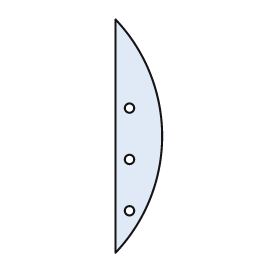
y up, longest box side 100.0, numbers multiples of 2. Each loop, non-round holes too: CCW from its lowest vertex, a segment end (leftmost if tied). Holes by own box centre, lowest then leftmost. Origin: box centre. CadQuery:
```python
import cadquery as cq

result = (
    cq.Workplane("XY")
    .moveTo(-10.0, -50.0)
    .threePointArc((10.0, 0.0), (-10.0, 50.0))
    .close()
    .moveTo(-4.0, -32.0)
    .circle(2.0)
    .moveTo(-4.0, -10.0)
    .circle(2.0)
    .moveTo(-4.0, 12.0)
    .circle(2.0)
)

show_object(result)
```